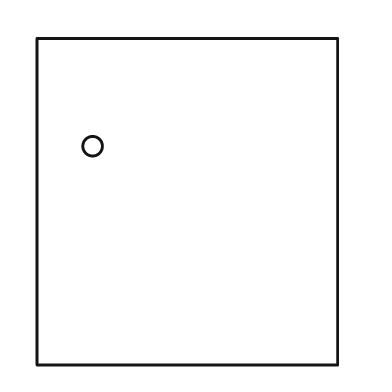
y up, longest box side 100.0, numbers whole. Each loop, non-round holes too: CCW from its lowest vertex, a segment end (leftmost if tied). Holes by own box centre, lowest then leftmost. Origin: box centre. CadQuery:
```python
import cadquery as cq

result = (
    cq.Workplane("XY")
    .moveTo(-46.0, -50.0)
    .lineTo(46.0, -50.0)
    .lineTo(46.0, 50.0)
    .lineTo(-46.0, 50.0)
    .close()
    .moveTo(-29.0, 17.0)
    .circle(3.0)
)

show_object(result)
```